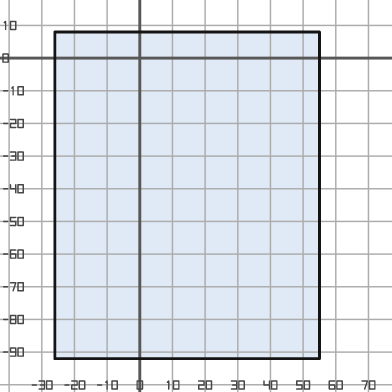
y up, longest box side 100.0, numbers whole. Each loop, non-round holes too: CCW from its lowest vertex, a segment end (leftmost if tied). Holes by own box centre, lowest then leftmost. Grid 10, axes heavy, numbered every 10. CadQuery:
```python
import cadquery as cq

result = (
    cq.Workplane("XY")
    .moveTo(-26.0, -92.0)
    .lineTo(55.0, -92.0)
    .lineTo(55.0, 8.0)
    .lineTo(-26.0, 8.0)
    .close()
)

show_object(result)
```